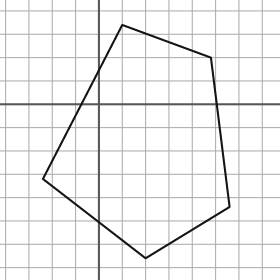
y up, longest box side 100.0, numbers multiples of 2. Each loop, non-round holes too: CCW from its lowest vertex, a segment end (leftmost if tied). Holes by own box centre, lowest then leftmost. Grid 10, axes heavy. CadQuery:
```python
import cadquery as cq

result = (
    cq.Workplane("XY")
    .moveTo(20.0, -66.0)
    .lineTo(56.0, -44.0)
    .lineTo(48.0, 20.0)
    .lineTo(10.0, 34.0)
    .lineTo(-24.0, -32.0)
    .close()
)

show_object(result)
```